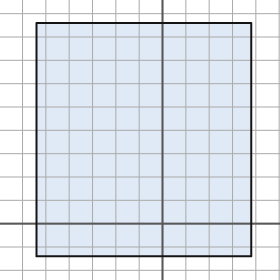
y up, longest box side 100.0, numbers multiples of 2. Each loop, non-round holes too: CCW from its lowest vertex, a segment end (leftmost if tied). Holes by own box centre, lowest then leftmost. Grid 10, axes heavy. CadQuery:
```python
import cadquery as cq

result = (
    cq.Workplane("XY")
    .moveTo(-54.0, -14.0)
    .lineTo(38.0, -14.0)
    .lineTo(38.0, 86.0)
    .lineTo(-54.0, 86.0)
    .close()
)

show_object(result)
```